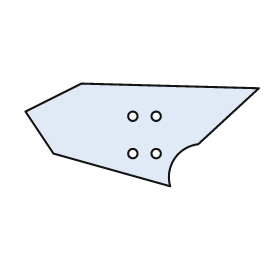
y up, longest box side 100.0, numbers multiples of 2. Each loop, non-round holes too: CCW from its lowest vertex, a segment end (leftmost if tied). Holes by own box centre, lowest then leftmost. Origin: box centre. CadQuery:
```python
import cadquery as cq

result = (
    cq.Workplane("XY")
    .moveTo(12.0, -22.0)
    .threePointArc((14.0, -10.0), (24.0, -4.0))
    .lineTo(50.0, 20.0)
    .lineTo(-26.0, 22.0)
    .lineTo(-50.0, 10.0)
    .lineTo(-38.0, -8.0)
    .close()
    .moveTo(-4.0, -8.0)
    .circle(2.0)
    .moveTo(6.0, -8.0)
    .circle(2.0)
    .moveTo(-4.0, 8.0)
    .circle(2.0)
    .moveTo(6.0, 8.0)
    .circle(2.0)
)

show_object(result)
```